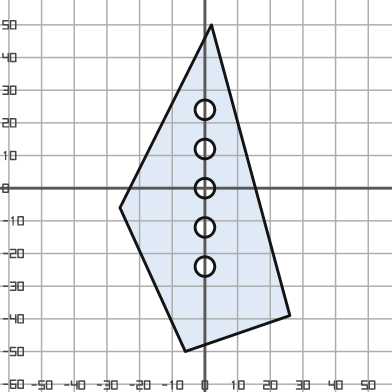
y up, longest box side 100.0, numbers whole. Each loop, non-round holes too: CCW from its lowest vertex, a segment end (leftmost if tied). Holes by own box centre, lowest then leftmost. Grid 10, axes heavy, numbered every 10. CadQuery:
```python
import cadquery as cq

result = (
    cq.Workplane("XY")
    .moveTo(-6.0, -50.0)
    .lineTo(26.0, -39.0)
    .lineTo(2.0, 50.0)
    .lineTo(-26.0, -6.0)
    .close()
    .moveTo(0.0, -24.0)
    .circle(3.0)
    .moveTo(0.0, -12.0)
    .circle(3.0)
    .moveTo(0.0, 0.0)
    .circle(3.0)
    .moveTo(0.0, 12.0)
    .circle(3.0)
    .moveTo(0.0, 24.0)
    .circle(3.0)
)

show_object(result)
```